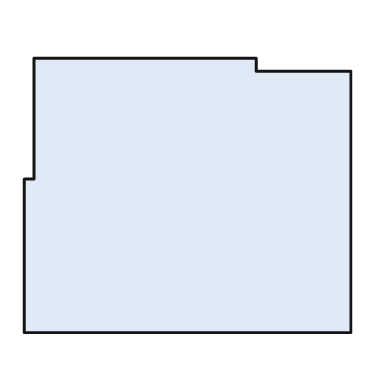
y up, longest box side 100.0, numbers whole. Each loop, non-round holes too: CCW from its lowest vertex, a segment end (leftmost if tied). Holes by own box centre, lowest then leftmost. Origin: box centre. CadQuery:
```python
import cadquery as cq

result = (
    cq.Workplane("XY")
    .moveTo(-50.0, -42.0)
    .lineTo(50.0, -42.0)
    .lineTo(50.0, 38.0)
    .lineTo(21.0, 38.0)
    .lineTo(21.0, 42.0)
    .lineTo(-47.0, 42.0)
    .lineTo(-47.0, 5.0)
    .lineTo(-50.0, 5.0)
    .close()
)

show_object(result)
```